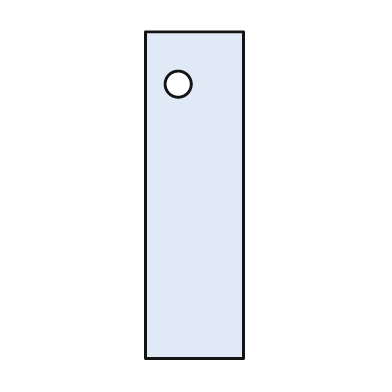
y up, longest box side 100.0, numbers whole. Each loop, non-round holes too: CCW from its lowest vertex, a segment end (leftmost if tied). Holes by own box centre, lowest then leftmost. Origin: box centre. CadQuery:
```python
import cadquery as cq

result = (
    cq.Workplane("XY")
    .moveTo(-15.0, -50.0)
    .lineTo(15.0, -50.0)
    .lineTo(15.0, 50.0)
    .lineTo(-15.0, 50.0)
    .close()
    .moveTo(-5.0, 34.0)
    .circle(4.0)
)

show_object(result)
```